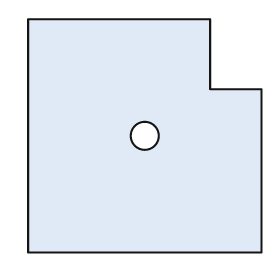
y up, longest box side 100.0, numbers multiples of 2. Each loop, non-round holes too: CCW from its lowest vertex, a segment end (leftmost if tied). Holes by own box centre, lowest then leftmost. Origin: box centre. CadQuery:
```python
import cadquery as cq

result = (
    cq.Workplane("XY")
    .moveTo(-50.0, -50.0)
    .lineTo(50.0, -50.0)
    .lineTo(50.0, 20.0)
    .lineTo(28.0, 20.0)
    .lineTo(28.0, 50.0)
    .lineTo(-50.0, 50.0)
    .close()
    .moveTo(0.0, 0.0)
    .circle(6.0)
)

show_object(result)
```